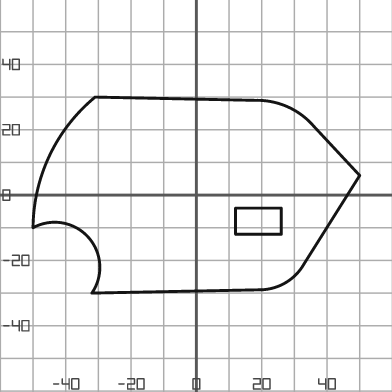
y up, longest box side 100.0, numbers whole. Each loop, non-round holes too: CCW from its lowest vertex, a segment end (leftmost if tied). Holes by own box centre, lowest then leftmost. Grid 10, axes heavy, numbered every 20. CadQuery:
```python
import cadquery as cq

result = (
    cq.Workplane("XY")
    .moveTo(-32.0, -30.0)
    .lineTo(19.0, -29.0)
    .threePointArc((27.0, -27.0), (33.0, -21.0))
    .lineTo(50.0, 6.0)
    .lineTo(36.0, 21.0)
    .threePointArc((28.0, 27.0), (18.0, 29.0))
    .lineTo(-31.0, 30.0)
    .threePointArc((-45.0, 12.0), (-50.0, -10.0))
    .threePointArc((-33.0, -13.0), (-32.0, -30.0))
    .close()
    .moveTo(12.0, -12.0)
    .lineTo(26.0, -12.0)
    .lineTo(26.0, -4.0)
    .lineTo(12.0, -4.0)
    .close()
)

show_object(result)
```